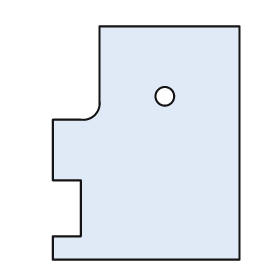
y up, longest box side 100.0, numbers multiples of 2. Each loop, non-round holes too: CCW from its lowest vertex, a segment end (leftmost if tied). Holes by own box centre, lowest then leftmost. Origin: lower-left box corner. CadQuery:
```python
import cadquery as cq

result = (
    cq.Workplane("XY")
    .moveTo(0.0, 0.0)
    .lineTo(80.0, 0.0)
    .lineTo(80.0, 100.0)
    .lineTo(20.0, 100.0)
    .lineTo(20.0, 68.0)
    .threePointArc((18.0, 62.0), (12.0, 60.0))
    .lineTo(0.0, 60.0)
    .lineTo(0.0, 34.0)
    .lineTo(12.0, 34.0)
    .lineTo(12.0, 10.0)
    .lineTo(0.0, 10.0)
    .close()
    .moveTo(48.0, 70.0)
    .circle(4.0)
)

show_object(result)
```